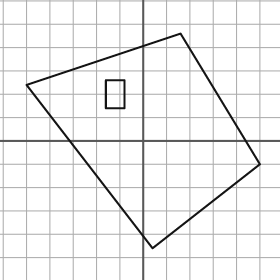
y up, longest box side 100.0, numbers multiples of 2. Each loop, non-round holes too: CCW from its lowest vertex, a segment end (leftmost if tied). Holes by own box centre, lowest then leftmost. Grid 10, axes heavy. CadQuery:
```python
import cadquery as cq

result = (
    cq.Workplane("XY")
    .moveTo(4.0, -46.0)
    .lineTo(50.0, -10.0)
    .lineTo(16.0, 46.0)
    .lineTo(-50.0, 24.0)
    .close()
    .moveTo(-16.0, 14.0)
    .lineTo(-8.0, 14.0)
    .lineTo(-8.0, 26.0)
    .lineTo(-16.0, 26.0)
    .close()
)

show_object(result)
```